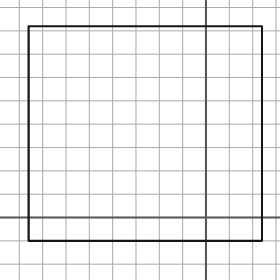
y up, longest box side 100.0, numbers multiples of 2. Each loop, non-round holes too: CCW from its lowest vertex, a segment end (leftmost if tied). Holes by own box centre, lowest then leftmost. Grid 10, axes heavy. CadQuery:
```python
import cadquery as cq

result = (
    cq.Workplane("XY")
    .moveTo(-76.0, -10.0)
    .lineTo(24.0, -10.0)
    .lineTo(24.0, 82.0)
    .lineTo(-76.0, 82.0)
    .close()
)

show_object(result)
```